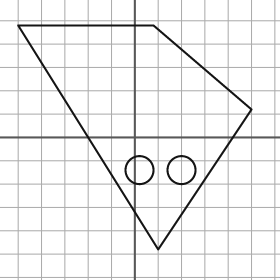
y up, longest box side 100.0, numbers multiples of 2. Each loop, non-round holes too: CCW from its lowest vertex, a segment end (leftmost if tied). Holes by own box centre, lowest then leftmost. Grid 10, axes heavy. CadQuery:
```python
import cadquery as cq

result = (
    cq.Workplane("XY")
    .moveTo(10.0, -48.0)
    .lineTo(50.0, 12.0)
    .lineTo(8.0, 48.0)
    .lineTo(-50.0, 48.0)
    .close()
    .moveTo(2.0, -14.0)
    .circle(6.0)
    .moveTo(20.0, -14.0)
    .circle(6.0)
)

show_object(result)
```